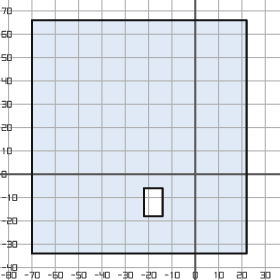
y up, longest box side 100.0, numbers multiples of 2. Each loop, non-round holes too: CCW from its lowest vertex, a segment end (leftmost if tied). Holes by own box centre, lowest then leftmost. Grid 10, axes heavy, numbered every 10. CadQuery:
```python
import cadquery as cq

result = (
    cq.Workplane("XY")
    .moveTo(-70.0, -34.0)
    .lineTo(22.0, -34.0)
    .lineTo(22.0, 66.0)
    .lineTo(-70.0, 66.0)
    .close()
    .moveTo(-22.0, -18.0)
    .lineTo(-14.0, -18.0)
    .lineTo(-14.0, -6.0)
    .lineTo(-22.0, -6.0)
    .close()
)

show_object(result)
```